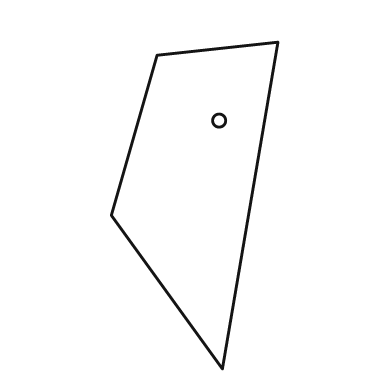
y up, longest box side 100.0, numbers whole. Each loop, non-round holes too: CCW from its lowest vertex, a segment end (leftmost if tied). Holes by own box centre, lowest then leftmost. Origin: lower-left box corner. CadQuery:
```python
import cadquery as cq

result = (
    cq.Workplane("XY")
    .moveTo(34.0, 0.0)
    .lineTo(51.0, 100.0)
    .lineTo(14.0, 96.0)
    .lineTo(0.0, 47.0)
    .close()
    .moveTo(33.0, 76.0)
    .circle(2.0)
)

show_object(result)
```